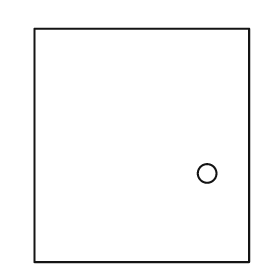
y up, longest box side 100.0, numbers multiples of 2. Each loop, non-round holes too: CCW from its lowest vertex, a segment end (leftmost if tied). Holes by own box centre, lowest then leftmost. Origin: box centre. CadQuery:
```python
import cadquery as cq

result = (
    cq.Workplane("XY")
    .moveTo(-46.0, -50.0)
    .lineTo(46.0, -50.0)
    .lineTo(46.0, 50.0)
    .lineTo(-46.0, 50.0)
    .close()
    .moveTo(28.0, -12.0)
    .circle(4.0)
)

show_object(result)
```